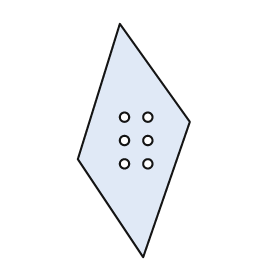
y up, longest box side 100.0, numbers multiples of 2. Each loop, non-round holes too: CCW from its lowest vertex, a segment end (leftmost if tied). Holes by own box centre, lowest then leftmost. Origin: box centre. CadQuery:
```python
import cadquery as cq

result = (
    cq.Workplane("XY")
    .moveTo(4.0, -50.0)
    .lineTo(24.0, 8.0)
    .lineTo(-6.0, 50.0)
    .lineTo(-24.0, -8.0)
    .close()
    .moveTo(-4.0, -10.0)
    .circle(2.0)
    .moveTo(6.0, -10.0)
    .circle(2.0)
    .moveTo(-4.0, 0.0)
    .circle(2.0)
    .moveTo(6.0, 0.0)
    .circle(2.0)
    .moveTo(-4.0, 10.0)
    .circle(2.0)
    .moveTo(6.0, 10.0)
    .circle(2.0)
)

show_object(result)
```